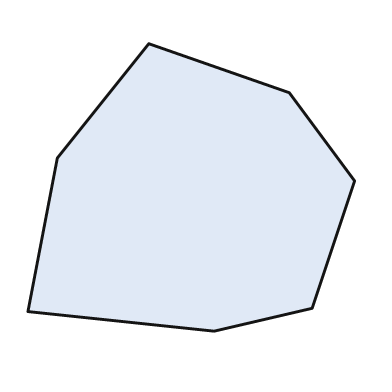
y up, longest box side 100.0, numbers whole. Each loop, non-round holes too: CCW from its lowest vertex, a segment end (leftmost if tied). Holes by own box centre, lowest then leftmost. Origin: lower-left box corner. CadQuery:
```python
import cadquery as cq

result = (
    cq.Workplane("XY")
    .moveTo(57.0, 0.0)
    .lineTo(87.0, 7.0)
    .lineTo(100.0, 46.0)
    .lineTo(80.0, 73.0)
    .lineTo(37.0, 88.0)
    .lineTo(9.0, 53.0)
    .lineTo(0.0, 6.0)
    .close()
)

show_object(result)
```